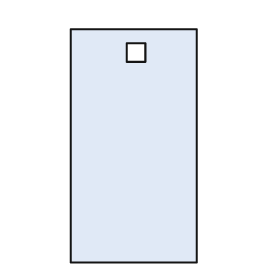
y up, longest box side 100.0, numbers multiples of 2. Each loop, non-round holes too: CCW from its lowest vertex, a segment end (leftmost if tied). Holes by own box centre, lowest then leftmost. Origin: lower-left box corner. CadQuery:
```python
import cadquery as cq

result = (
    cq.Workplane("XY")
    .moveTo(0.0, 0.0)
    .lineTo(54.0, 0.0)
    .lineTo(54.0, 100.0)
    .lineTo(0.0, 100.0)
    .close()
    .moveTo(24.0, 86.0)
    .lineTo(32.0, 86.0)
    .lineTo(32.0, 94.0)
    .lineTo(24.0, 94.0)
    .close()
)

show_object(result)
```